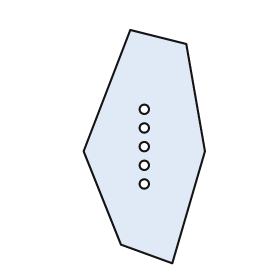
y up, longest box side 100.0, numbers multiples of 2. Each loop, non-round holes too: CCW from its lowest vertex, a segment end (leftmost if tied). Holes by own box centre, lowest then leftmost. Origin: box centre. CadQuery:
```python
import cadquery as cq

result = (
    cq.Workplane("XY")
    .moveTo(12.0, -50.0)
    .lineTo(26.0, -2.0)
    .lineTo(18.0, 44.0)
    .lineTo(-6.0, 50.0)
    .lineTo(-26.0, -2.0)
    .lineTo(-10.0, -42.0)
    .close()
    .moveTo(0.0, -16.0)
    .circle(2.0)
    .moveTo(0.0, -8.0)
    .circle(2.0)
    .moveTo(0.0, 0.0)
    .circle(2.0)
    .moveTo(0.0, 8.0)
    .circle(2.0)
    .moveTo(0.0, 16.0)
    .circle(2.0)
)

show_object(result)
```